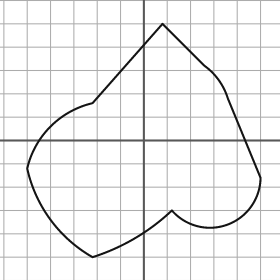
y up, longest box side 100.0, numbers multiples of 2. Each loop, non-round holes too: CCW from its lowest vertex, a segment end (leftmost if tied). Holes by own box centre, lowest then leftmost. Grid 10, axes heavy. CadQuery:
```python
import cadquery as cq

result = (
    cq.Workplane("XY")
    .moveTo(-22.0, -50.0)
    .threePointArc((-4.0, -42.0), (12.0, -30.0))
    .threePointArc((36.0, -36.0), (50.0, -16.0))
    .lineTo(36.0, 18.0)
    .threePointArc((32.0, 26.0), (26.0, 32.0))
    .lineTo(8.0, 50.0)
    .lineTo(-22.0, 16.0)
    .threePointArc((-40.0, 6.0), (-50.0, -12.0))
    .threePointArc((-40.0, -34.0), (-22.0, -50.0))
    .close()
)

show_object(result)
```